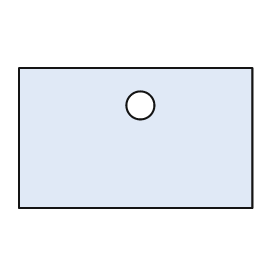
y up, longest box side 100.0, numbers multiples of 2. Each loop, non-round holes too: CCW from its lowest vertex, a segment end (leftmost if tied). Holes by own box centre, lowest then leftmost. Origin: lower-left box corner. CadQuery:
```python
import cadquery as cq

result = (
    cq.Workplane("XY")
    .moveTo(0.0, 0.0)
    .lineTo(100.0, 0.0)
    .lineTo(100.0, 60.0)
    .lineTo(0.0, 60.0)
    .close()
    .moveTo(52.0, 44.0)
    .circle(6.0)
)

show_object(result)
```